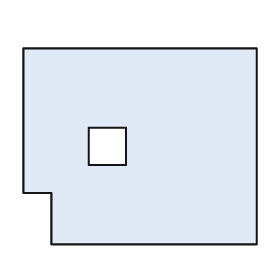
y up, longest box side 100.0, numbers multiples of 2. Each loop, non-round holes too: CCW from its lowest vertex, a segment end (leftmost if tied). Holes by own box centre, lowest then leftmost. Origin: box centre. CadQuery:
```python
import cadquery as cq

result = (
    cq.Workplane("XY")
    .moveTo(-38.0, -42.0)
    .lineTo(50.0, -42.0)
    .lineTo(50.0, 42.0)
    .lineTo(-50.0, 42.0)
    .lineTo(-50.0, -20.0)
    .lineTo(-38.0, -20.0)
    .close()
    .moveTo(-22.0, -8.0)
    .lineTo(-6.0, -8.0)
    .lineTo(-6.0, 8.0)
    .lineTo(-22.0, 8.0)
    .close()
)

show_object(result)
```